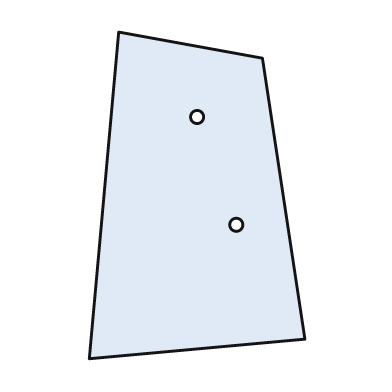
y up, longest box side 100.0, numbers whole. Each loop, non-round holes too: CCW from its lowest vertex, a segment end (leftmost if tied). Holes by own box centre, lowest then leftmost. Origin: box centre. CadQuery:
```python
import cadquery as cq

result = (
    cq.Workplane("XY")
    .moveTo(-33.0, -50.0)
    .lineTo(33.0, -44.0)
    .lineTo(20.0, 42.0)
    .lineTo(-24.0, 50.0)
    .close()
    .moveTo(12.0, -9.0)
    .circle(2.0)
    .moveTo(0.0, 24.0)
    .circle(2.0)
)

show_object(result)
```